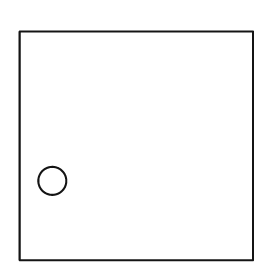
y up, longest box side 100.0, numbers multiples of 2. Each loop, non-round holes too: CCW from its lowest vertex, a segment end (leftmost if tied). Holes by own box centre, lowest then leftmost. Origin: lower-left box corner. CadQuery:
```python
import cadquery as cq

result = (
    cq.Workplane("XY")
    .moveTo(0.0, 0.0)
    .lineTo(100.0, 0.0)
    .lineTo(100.0, 98.0)
    .lineTo(0.0, 98.0)
    .close()
    .moveTo(14.0, 34.0)
    .circle(6.0)
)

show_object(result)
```